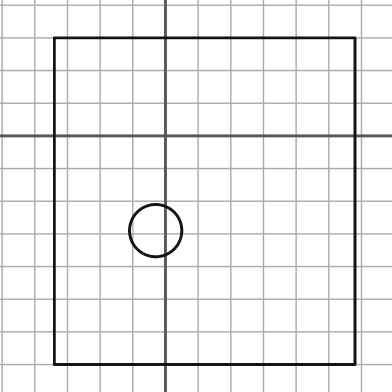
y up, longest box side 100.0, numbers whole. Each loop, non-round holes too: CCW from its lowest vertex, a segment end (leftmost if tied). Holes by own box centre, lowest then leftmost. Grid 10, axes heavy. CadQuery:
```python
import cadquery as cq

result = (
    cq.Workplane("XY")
    .moveTo(-34.0, -70.0)
    .lineTo(58.0, -70.0)
    .lineTo(58.0, 30.0)
    .lineTo(-34.0, 30.0)
    .close()
    .moveTo(-3.0, -29.0)
    .circle(8.0)
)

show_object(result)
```